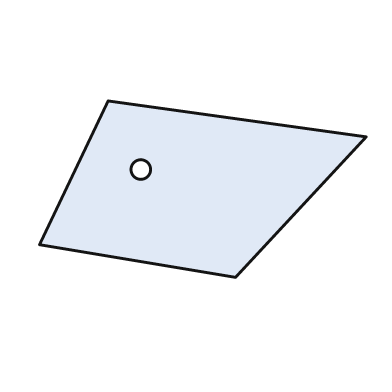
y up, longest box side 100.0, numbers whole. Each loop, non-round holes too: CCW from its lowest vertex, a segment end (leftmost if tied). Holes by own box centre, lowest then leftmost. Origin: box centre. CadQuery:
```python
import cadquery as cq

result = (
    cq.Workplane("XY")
    .moveTo(10.0, -27.0)
    .lineTo(50.0, 16.0)
    .lineTo(-29.0, 27.0)
    .lineTo(-50.0, -17.0)
    .close()
    .moveTo(-19.0, 6.0)
    .circle(3.0)
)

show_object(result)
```